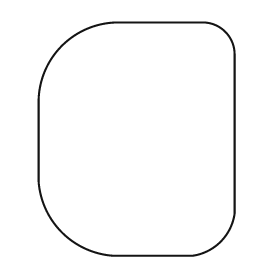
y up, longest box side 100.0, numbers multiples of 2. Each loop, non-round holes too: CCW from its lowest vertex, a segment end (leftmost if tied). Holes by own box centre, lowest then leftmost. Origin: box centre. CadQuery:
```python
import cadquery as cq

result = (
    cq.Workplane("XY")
    .moveTo(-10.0, -50.0)
    .lineTo(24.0, -50.0)
    .threePointArc((36.0, -44.0), (42.0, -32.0))
    .lineTo(42.0, 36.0)
    .threePointArc((38.0, 46.0), (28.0, 50.0))
    .lineTo(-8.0, 50.0)
    .threePointArc((-32.0, 40.0), (-42.0, 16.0))
    .lineTo(-42.0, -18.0)
    .threePointArc((-32.0, -40.0), (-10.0, -50.0))
    .close()
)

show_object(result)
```